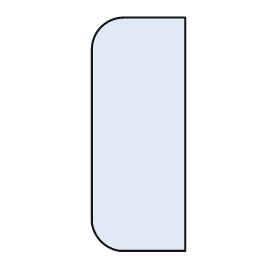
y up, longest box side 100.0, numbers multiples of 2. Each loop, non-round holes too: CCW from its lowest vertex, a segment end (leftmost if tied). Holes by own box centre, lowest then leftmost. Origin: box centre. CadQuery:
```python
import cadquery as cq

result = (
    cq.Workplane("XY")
    .moveTo(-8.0, -50.0)
    .lineTo(20.0, -50.0)
    .lineTo(20.0, 50.0)
    .lineTo(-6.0, 50.0)
    .threePointArc((-16.0, 46.0), (-20.0, 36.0))
    .lineTo(-20.0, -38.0)
    .threePointArc((-16.0, -46.0), (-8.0, -50.0))
    .close()
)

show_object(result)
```